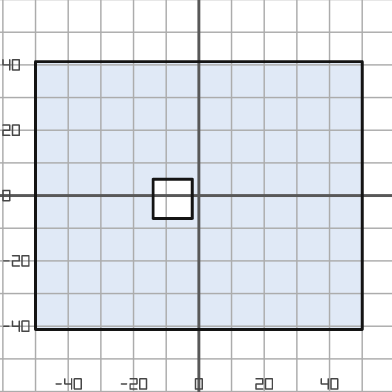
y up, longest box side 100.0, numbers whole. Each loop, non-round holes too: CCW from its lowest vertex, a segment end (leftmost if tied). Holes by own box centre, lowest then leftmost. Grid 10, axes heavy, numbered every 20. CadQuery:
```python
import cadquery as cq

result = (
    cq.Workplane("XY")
    .moveTo(-50.0, -41.0)
    .lineTo(50.0, -41.0)
    .lineTo(50.0, 41.0)
    .lineTo(-50.0, 41.0)
    .close()
    .moveTo(-14.0, -7.0)
    .lineTo(-2.0, -7.0)
    .lineTo(-2.0, 5.0)
    .lineTo(-14.0, 5.0)
    .close()
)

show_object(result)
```